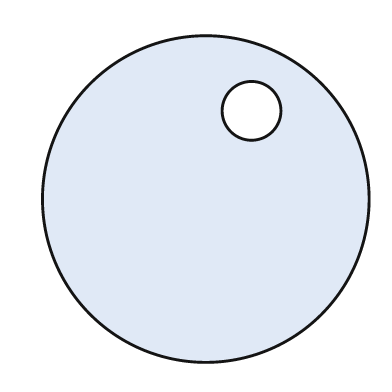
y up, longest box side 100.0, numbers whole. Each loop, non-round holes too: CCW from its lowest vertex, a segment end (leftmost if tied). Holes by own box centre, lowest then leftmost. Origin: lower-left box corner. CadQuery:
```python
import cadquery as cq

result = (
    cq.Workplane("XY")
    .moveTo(50.0, 50.0)
    .circle(50.0)
    .moveTo(64.0, 77.0)
    .circle(9.0)
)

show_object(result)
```